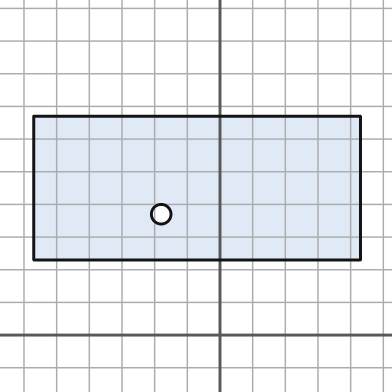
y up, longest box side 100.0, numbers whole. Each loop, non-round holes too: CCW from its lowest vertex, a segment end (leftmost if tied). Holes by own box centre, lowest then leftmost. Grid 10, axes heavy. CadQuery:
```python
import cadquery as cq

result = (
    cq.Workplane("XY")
    .moveTo(-57.0, 23.0)
    .lineTo(43.0, 23.0)
    .lineTo(43.0, 67.0)
    .lineTo(-57.0, 67.0)
    .close()
    .moveTo(-18.0, 37.0)
    .circle(3.0)
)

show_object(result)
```